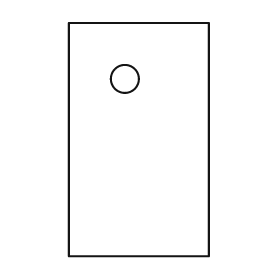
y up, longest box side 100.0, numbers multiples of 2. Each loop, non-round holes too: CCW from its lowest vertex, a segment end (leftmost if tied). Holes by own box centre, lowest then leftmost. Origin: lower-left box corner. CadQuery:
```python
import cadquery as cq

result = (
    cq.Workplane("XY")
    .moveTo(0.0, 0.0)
    .lineTo(60.0, 0.0)
    .lineTo(60.0, 100.0)
    .lineTo(0.0, 100.0)
    .close()
    .moveTo(24.0, 76.0)
    .circle(6.0)
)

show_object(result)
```